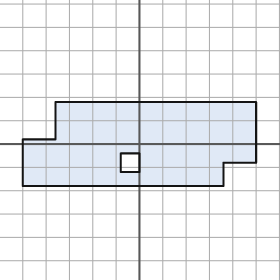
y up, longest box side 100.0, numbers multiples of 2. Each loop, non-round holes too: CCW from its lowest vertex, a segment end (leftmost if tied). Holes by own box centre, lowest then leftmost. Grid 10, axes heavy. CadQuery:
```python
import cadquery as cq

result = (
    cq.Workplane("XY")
    .moveTo(-50.0, -18.0)
    .lineTo(36.0, -18.0)
    .lineTo(36.0, -8.0)
    .lineTo(50.0, -8.0)
    .lineTo(50.0, 18.0)
    .lineTo(-36.0, 18.0)
    .lineTo(-36.0, 2.0)
    .lineTo(-50.0, 2.0)
    .close()
    .moveTo(-8.0, -12.0)
    .lineTo(0.0, -12.0)
    .lineTo(0.0, -4.0)
    .lineTo(-8.0, -4.0)
    .close()
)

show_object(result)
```